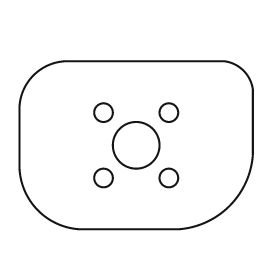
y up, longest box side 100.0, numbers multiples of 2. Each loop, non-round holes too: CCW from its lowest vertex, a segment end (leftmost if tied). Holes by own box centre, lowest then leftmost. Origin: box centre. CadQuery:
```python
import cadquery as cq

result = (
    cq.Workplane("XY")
    .moveTo(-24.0, -36.0)
    .lineTo(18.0, -36.0)
    .threePointArc((40.0, -26.0), (50.0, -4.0))
    .lineTo(50.0, 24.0)
    .threePointArc((46.0, 32.0), (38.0, 36.0))
    .lineTo(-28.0, 36.0)
    .threePointArc((-44.0, 30.0), (-50.0, 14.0))
    .lineTo(-50.0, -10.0)
    .threePointArc((-42.0, -28.0), (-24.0, -36.0))
    .close()
    .moveTo(-14.0, -14.0)
    .circle(4.0)
    .moveTo(14.0, -14.0)
    .circle(4.0)
    .moveTo(0.0, 0.0)
    .circle(10.0)
    .moveTo(-14.0, 14.0)
    .circle(4.0)
    .moveTo(14.0, 14.0)
    .circle(4.0)
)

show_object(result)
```